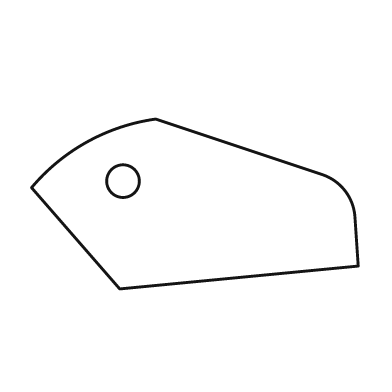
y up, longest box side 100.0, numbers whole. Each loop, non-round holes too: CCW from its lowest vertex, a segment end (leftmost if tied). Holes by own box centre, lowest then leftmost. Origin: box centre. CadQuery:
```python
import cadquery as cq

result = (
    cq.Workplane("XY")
    .moveTo(-23.0, -26.0)
    .lineTo(50.0, -19.0)
    .lineTo(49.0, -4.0)
    .threePointArc((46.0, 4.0), (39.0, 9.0))
    .lineTo(-12.0, 26.0)
    .threePointArc((-33.0, 19.0), (-50.0, 5.0))
    .close()
    .moveTo(-22.0, 7.0)
    .circle(5.0)
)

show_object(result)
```